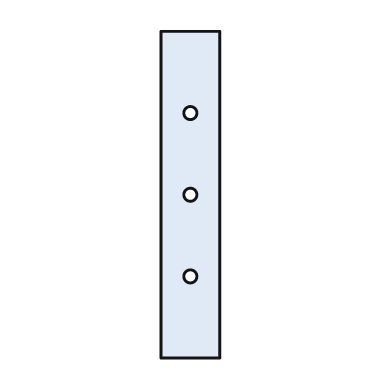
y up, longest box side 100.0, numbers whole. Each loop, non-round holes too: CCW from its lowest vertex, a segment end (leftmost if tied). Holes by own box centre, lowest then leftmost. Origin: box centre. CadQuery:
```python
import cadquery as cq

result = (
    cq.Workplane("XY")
    .moveTo(-9.0, -50.0)
    .lineTo(9.0, -50.0)
    .lineTo(9.0, 50.0)
    .lineTo(-9.0, 50.0)
    .close()
    .moveTo(0.0, -25.0)
    .circle(2.0)
    .moveTo(0.0, 0.0)
    .circle(2.0)
    .moveTo(0.0, 25.0)
    .circle(2.0)
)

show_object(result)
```